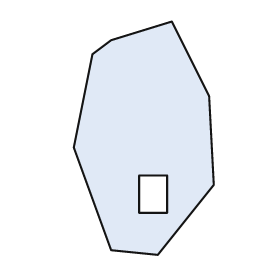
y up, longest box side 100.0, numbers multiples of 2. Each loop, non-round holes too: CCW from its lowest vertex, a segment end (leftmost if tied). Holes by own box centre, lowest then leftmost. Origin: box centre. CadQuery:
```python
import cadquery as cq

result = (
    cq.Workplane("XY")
    .moveTo(6.0, -50.0)
    .lineTo(30.0, -20.0)
    .lineTo(28.0, 18.0)
    .lineTo(12.0, 50.0)
    .lineTo(-14.0, 42.0)
    .lineTo(-22.0, 36.0)
    .lineTo(-30.0, -4.0)
    .lineTo(-14.0, -48.0)
    .close()
    .moveTo(-2.0, -32.0)
    .lineTo(10.0, -32.0)
    .lineTo(10.0, -16.0)
    .lineTo(-2.0, -16.0)
    .close()
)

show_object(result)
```